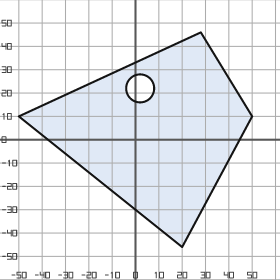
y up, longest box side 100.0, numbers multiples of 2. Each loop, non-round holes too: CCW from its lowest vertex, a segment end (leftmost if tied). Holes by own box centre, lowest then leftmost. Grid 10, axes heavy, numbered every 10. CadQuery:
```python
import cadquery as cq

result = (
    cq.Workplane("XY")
    .moveTo(20.0, -46.0)
    .lineTo(50.0, 10.0)
    .lineTo(28.0, 46.0)
    .lineTo(-50.0, 10.0)
    .close()
    .moveTo(2.0, 22.0)
    .circle(6.0)
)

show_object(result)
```